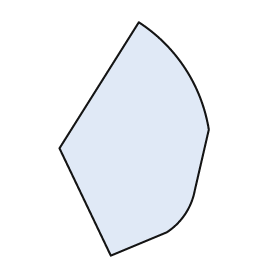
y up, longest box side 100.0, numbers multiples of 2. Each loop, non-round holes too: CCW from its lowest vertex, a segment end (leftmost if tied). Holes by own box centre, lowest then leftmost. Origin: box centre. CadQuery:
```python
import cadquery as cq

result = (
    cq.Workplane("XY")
    .moveTo(-10.0, -50.0)
    .lineTo(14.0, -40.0)
    .threePointArc((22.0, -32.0), (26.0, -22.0))
    .lineTo(32.0, 4.0)
    .threePointArc((22.0, 30.0), (2.0, 50.0))
    .lineTo(-32.0, -4.0)
    .close()
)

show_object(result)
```